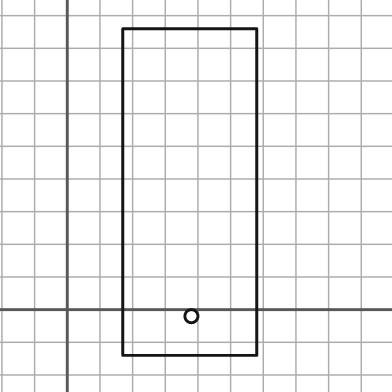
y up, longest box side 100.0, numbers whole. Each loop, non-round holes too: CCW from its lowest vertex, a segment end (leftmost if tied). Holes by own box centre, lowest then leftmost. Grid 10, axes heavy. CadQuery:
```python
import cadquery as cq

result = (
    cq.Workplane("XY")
    .moveTo(17.0, -14.0)
    .lineTo(58.0, -14.0)
    .lineTo(58.0, 86.0)
    .lineTo(17.0, 86.0)
    .close()
    .moveTo(38.0, -2.0)
    .circle(2.0)
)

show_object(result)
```